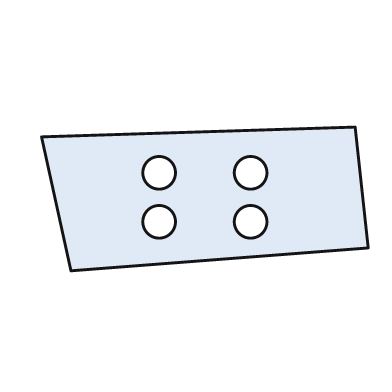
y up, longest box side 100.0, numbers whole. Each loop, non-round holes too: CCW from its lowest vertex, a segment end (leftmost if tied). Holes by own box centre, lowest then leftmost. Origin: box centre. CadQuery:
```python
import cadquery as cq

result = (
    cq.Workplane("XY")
    .moveTo(-41.0, -22.0)
    .lineTo(50.0, -15.0)
    .lineTo(46.0, 22.0)
    .lineTo(-50.0, 19.0)
    .close()
    .moveTo(-14.0, -7.0)
    .circle(5.0)
    .moveTo(14.0, -7.0)
    .circle(5.0)
    .moveTo(-14.0, 8.0)
    .circle(5.0)
    .moveTo(14.0, 8.0)
    .circle(5.0)
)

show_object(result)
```